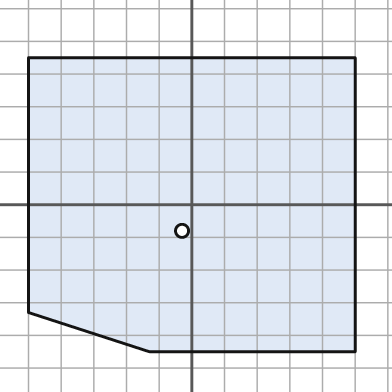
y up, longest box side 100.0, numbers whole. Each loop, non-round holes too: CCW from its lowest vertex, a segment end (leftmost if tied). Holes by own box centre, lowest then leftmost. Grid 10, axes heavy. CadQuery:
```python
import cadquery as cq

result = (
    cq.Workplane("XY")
    .moveTo(-13.0, -45.0)
    .lineTo(50.0, -45.0)
    .lineTo(50.0, 45.0)
    .lineTo(-50.0, 45.0)
    .lineTo(-50.0, -33.0)
    .close()
    .moveTo(-3.0, -8.0)
    .circle(2.0)
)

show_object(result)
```